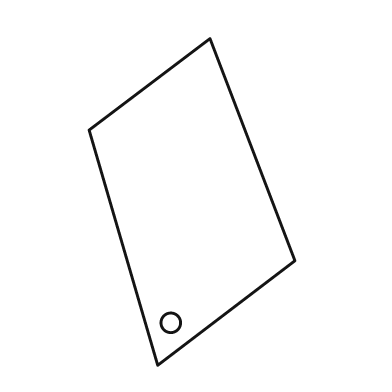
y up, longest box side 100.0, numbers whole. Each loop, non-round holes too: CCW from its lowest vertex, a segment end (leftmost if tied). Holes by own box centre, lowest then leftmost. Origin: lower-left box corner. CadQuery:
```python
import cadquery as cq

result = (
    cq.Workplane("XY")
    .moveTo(21.0, 0.0)
    .lineTo(63.0, 32.0)
    .lineTo(37.0, 100.0)
    .lineTo(0.0, 72.0)
    .close()
    .moveTo(25.0, 13.0)
    .circle(3.0)
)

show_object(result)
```